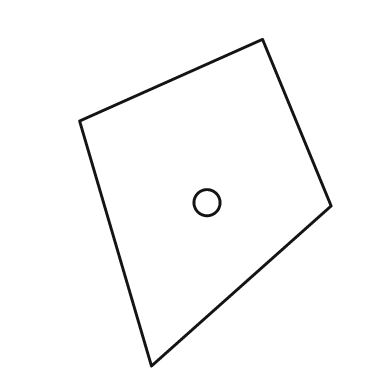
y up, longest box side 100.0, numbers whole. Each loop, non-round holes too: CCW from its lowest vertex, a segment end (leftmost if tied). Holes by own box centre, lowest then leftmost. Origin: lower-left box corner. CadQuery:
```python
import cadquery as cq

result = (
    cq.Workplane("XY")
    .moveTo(22.0, 0.0)
    .lineTo(77.0, 49.0)
    .lineTo(56.0, 100.0)
    .lineTo(0.0, 75.0)
    .close()
    .moveTo(39.0, 50.0)
    .circle(4.0)
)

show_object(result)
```